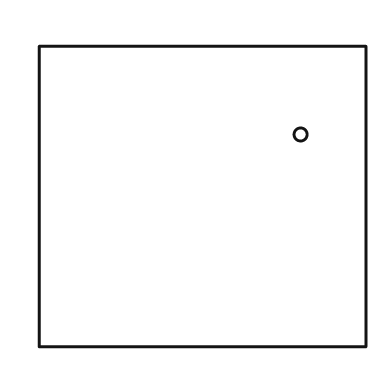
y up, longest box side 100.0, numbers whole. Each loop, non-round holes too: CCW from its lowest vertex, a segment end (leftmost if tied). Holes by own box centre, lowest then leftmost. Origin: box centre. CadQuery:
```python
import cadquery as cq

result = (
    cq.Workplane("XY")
    .moveTo(-50.0, -46.0)
    .lineTo(50.0, -46.0)
    .lineTo(50.0, 46.0)
    .lineTo(-50.0, 46.0)
    .close()
    .moveTo(30.0, 19.0)
    .circle(2.0)
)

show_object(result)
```